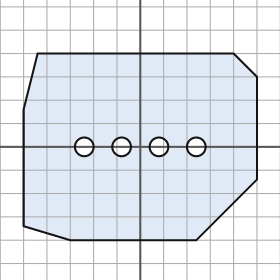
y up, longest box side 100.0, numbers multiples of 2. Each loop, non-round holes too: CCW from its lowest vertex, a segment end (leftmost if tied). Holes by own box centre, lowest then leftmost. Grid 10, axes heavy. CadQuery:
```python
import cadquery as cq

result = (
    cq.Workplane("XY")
    .moveTo(-30.0, -40.0)
    .lineTo(24.0, -40.0)
    .lineTo(50.0, -14.0)
    .lineTo(50.0, 30.0)
    .lineTo(40.0, 40.0)
    .lineTo(-44.0, 40.0)
    .lineTo(-50.0, 16.0)
    .lineTo(-50.0, -34.0)
    .close()
    .moveTo(-24.0, 0.0)
    .circle(4.0)
    .moveTo(-8.0, 0.0)
    .circle(4.0)
    .moveTo(8.0, 0.0)
    .circle(4.0)
    .moveTo(24.0, 0.0)
    .circle(4.0)
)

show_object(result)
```